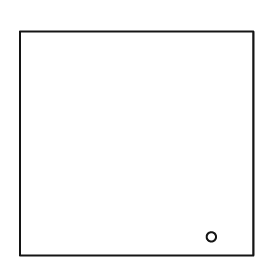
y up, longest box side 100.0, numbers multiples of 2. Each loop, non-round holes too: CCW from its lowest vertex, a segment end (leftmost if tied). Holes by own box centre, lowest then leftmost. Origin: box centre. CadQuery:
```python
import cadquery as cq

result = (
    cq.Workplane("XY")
    .moveTo(-50.0, -48.0)
    .lineTo(50.0, -48.0)
    .lineTo(50.0, 48.0)
    .lineTo(-50.0, 48.0)
    .close()
    .moveTo(32.0, -40.0)
    .circle(2.0)
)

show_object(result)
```